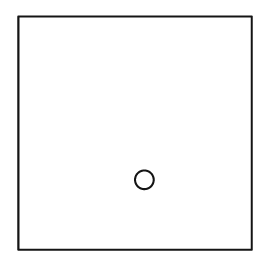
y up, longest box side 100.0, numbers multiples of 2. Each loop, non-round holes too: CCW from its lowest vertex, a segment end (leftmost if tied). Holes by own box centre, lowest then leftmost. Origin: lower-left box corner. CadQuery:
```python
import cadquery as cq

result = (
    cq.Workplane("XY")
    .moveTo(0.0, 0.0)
    .lineTo(100.0, 0.0)
    .lineTo(100.0, 100.0)
    .lineTo(0.0, 100.0)
    .close()
    .moveTo(54.0, 30.0)
    .circle(4.0)
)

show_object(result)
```